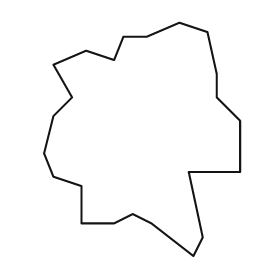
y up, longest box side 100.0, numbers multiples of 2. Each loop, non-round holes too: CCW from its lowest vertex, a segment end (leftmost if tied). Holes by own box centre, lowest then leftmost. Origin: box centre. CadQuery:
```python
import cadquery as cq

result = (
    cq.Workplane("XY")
    .moveTo(22.0, -50.0)
    .lineTo(26.0, -42.0)
    .lineTo(20.0, -14.0)
    .lineTo(42.0, -14.0)
    .lineTo(42.0, 8.0)
    .lineTo(32.0, 18.0)
    .lineTo(32.0, 28.0)
    .lineTo(28.0, 46.0)
    .lineTo(16.0, 50.0)
    .lineTo(2.0, 44.0)
    .lineTo(-8.0, 44.0)
    .lineTo(-12.0, 34.0)
    .lineTo(-24.0, 38.0)
    .lineTo(-38.0, 32.0)
    .lineTo(-30.0, 18.0)
    .lineTo(-38.0, 10.0)
    .lineTo(-42.0, -6.0)
    .lineTo(-38.0, -16.0)
    .lineTo(-26.0, -20.0)
    .lineTo(-26.0, -36.0)
    .lineTo(-12.0, -36.0)
    .lineTo(-4.0, -32.0)
    .lineTo(4.0, -36.0)
    .close()
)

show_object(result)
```